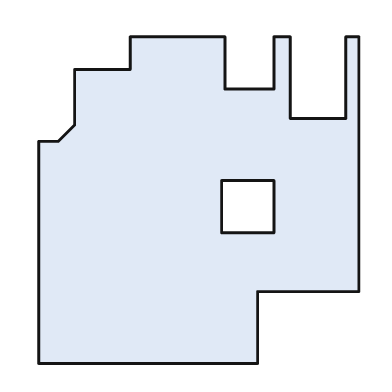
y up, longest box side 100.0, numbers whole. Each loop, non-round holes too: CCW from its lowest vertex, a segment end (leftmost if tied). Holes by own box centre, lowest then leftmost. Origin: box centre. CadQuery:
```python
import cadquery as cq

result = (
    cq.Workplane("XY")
    .moveTo(-49.0, -50.0)
    .lineTo(18.0, -50.0)
    .lineTo(18.0, -28.0)
    .lineTo(49.0, -28.0)
    .lineTo(49.0, 50.0)
    .lineTo(45.0, 50.0)
    .lineTo(45.0, 25.0)
    .lineTo(28.0, 25.0)
    .lineTo(28.0, 50.0)
    .lineTo(23.0, 50.0)
    .lineTo(23.0, 34.0)
    .lineTo(8.0, 34.0)
    .lineTo(8.0, 50.0)
    .lineTo(-21.0, 50.0)
    .lineTo(-21.0, 40.0)
    .lineTo(-38.0, 40.0)
    .lineTo(-38.0, 23.0)
    .lineTo(-43.0, 18.0)
    .lineTo(-49.0, 18.0)
    .close()
    .moveTo(7.0, -10.0)
    .lineTo(23.0, -10.0)
    .lineTo(23.0, 6.0)
    .lineTo(7.0, 6.0)
    .close()
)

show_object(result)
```